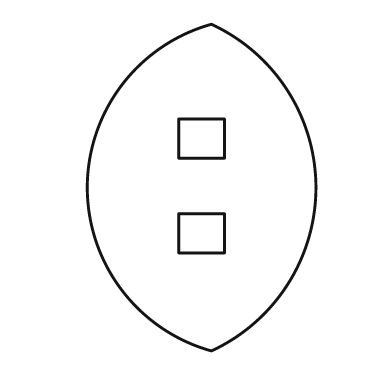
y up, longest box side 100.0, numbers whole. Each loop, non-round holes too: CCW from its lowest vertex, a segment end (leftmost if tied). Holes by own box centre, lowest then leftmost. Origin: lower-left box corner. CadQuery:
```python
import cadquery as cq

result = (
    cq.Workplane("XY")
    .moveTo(38.0, 0.0)
    .threePointArc((70.0, 50.0), (38.0, 100.0))
    .threePointArc((0.0, 50.0), (38.0, 0.0))
    .close()
    .moveTo(28.0, 30.0)
    .lineTo(42.0, 30.0)
    .lineTo(42.0, 42.0)
    .lineTo(28.0, 42.0)
    .close()
    .moveTo(28.0, 59.0)
    .lineTo(42.0, 59.0)
    .lineTo(42.0, 71.0)
    .lineTo(28.0, 71.0)
    .close()
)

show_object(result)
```